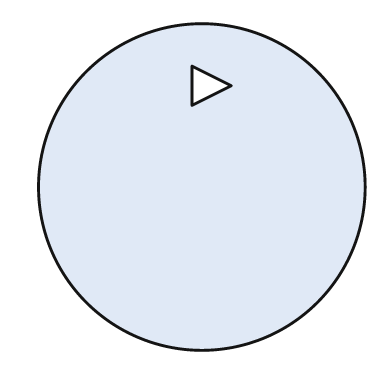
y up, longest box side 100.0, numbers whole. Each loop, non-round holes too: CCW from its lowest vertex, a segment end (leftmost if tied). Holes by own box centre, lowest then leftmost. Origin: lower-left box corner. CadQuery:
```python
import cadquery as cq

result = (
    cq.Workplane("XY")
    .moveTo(50.0, 50.0)
    .circle(50.0)
    .moveTo(47.0, 75.0)
    .lineTo(59.0, 81.0)
    .lineTo(47.0, 87.0)
    .close()
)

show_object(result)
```